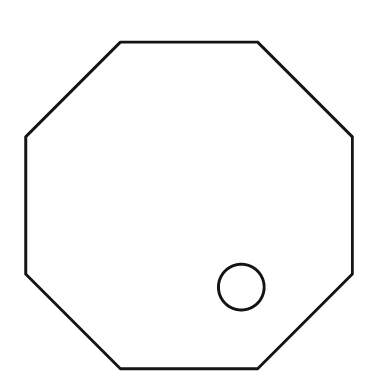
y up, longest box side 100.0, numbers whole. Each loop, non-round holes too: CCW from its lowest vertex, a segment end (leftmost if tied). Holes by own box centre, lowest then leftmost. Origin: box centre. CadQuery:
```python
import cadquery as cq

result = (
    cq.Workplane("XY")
    .moveTo(-21.0, -50.0)
    .lineTo(21.0, -50.0)
    .lineTo(50.0, -21.0)
    .lineTo(50.0, 21.0)
    .lineTo(21.0, 50.0)
    .lineTo(-21.0, 50.0)
    .lineTo(-50.0, 21.0)
    .lineTo(-50.0, -21.0)
    .close()
    .moveTo(16.0, -25.0)
    .circle(7.0)
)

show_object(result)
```